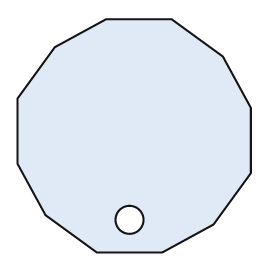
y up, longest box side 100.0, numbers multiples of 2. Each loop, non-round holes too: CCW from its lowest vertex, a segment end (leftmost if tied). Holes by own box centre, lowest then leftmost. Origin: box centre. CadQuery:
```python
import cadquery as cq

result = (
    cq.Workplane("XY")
    .moveTo(-16.0, -50.0)
    .lineTo(12.0, -50.0)
    .lineTo(34.0, -38.0)
    .lineTo(50.0, -16.0)
    .lineTo(50.0, 12.0)
    .lineTo(38.0, 34.0)
    .lineTo(16.0, 50.0)
    .lineTo(-12.0, 50.0)
    .lineTo(-34.0, 38.0)
    .lineTo(-50.0, 16.0)
    .lineTo(-50.0, -12.0)
    .lineTo(-38.0, -34.0)
    .close()
    .moveTo(-2.0, -36.0)
    .circle(6.0)
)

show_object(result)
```